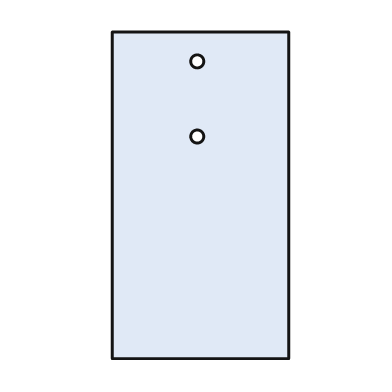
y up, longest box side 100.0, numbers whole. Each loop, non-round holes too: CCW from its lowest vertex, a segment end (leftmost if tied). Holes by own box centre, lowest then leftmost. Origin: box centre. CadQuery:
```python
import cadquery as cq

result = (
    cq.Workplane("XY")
    .moveTo(-27.0, -50.0)
    .lineTo(27.0, -50.0)
    .lineTo(27.0, 50.0)
    .lineTo(-27.0, 50.0)
    .close()
    .moveTo(-1.0, 18.0)
    .circle(2.0)
    .moveTo(-1.0, 41.0)
    .circle(2.0)
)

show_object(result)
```